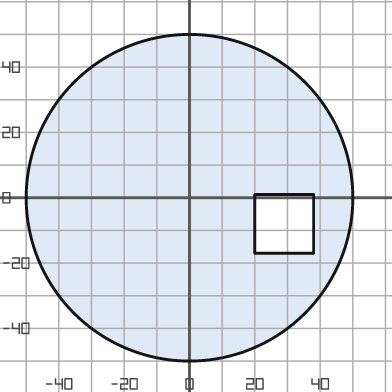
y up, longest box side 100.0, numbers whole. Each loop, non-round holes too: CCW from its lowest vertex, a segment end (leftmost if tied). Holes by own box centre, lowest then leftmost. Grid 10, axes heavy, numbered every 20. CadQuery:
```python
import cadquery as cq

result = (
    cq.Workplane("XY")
    .moveTo(0.0, 0.0)
    .circle(50.0)
    .moveTo(20.0, -17.0)
    .lineTo(38.0, -17.0)
    .lineTo(38.0, 1.0)
    .lineTo(20.0, 1.0)
    .close()
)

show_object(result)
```